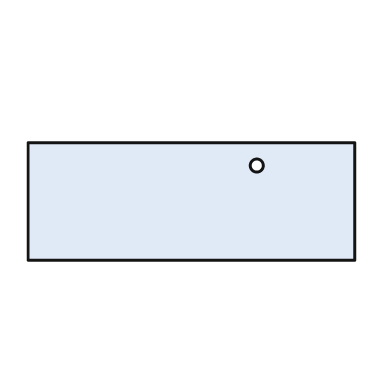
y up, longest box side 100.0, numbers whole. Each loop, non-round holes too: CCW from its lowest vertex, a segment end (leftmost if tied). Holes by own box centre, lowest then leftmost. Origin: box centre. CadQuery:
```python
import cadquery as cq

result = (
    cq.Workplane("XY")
    .moveTo(-50.0, -18.0)
    .lineTo(50.0, -18.0)
    .lineTo(50.0, 18.0)
    .lineTo(-50.0, 18.0)
    .close()
    .moveTo(20.0, 11.0)
    .circle(2.0)
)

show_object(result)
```